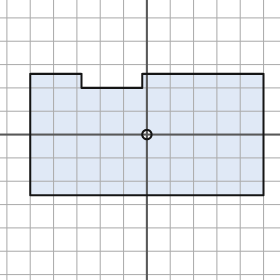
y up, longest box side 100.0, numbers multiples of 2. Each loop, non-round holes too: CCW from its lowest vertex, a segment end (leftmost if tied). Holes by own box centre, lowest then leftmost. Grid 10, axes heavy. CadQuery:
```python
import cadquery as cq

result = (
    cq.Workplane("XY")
    .moveTo(-50.0, -26.0)
    .lineTo(50.0, -26.0)
    .lineTo(50.0, 26.0)
    .lineTo(-2.0, 26.0)
    .lineTo(-2.0, 20.0)
    .lineTo(-28.0, 20.0)
    .lineTo(-28.0, 26.0)
    .lineTo(-50.0, 26.0)
    .close()
    .moveTo(0.0, 0.0)
    .circle(2.0)
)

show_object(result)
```